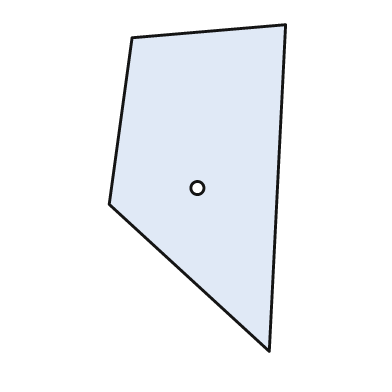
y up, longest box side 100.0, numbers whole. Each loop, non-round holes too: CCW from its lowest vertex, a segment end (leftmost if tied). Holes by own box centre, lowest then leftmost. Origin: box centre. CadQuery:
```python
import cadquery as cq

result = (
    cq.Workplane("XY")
    .moveTo(22.0, -50.0)
    .lineTo(27.0, 50.0)
    .lineTo(-20.0, 46.0)
    .lineTo(-27.0, -5.0)
    .close()
    .moveTo(0.0, 0.0)
    .circle(2.0)
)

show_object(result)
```